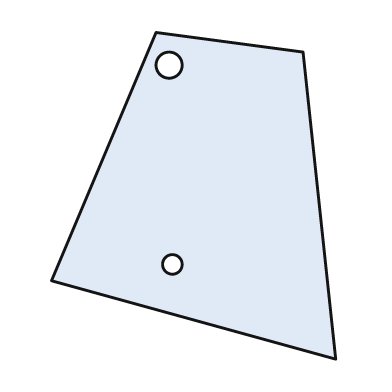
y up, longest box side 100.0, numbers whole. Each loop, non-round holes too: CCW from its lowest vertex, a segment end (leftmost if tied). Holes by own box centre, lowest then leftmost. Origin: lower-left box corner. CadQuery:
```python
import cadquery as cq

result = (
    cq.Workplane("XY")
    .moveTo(87.0, 0.0)
    .lineTo(77.0, 94.0)
    .lineTo(32.0, 100.0)
    .lineTo(0.0, 24.0)
    .close()
    .moveTo(37.0, 29.0)
    .circle(3.0)
    .moveTo(36.0, 90.0)
    .circle(4.0)
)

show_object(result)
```